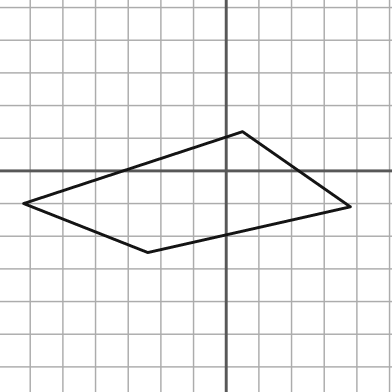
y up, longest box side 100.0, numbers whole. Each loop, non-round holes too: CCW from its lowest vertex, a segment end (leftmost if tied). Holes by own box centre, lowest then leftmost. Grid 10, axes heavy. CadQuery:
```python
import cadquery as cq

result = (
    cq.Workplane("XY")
    .moveTo(-24.0, -25.0)
    .lineTo(38.0, -11.0)
    .lineTo(5.0, 12.0)
    .lineTo(-62.0, -10.0)
    .close()
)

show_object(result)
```